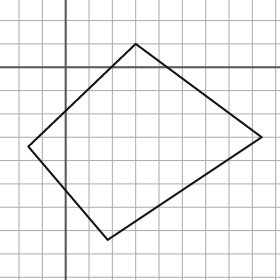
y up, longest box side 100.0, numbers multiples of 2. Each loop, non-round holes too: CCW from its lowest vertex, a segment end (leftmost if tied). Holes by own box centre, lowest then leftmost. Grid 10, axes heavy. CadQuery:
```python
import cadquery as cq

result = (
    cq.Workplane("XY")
    .moveTo(18.0, -74.0)
    .lineTo(84.0, -30.0)
    .lineTo(30.0, 10.0)
    .lineTo(-16.0, -34.0)
    .close()
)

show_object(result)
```